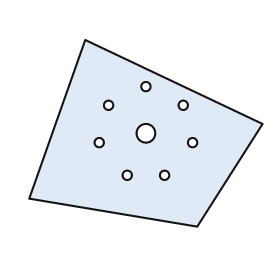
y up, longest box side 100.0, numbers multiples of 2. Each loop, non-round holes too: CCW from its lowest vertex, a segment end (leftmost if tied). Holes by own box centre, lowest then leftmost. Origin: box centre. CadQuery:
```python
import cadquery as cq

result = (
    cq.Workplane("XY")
    .moveTo(22.0, -40.0)
    .lineTo(50.0, 4.0)
    .lineTo(-26.0, 40.0)
    .lineTo(-50.0, -28.0)
    .close()
    .moveTo(-8.0, -18.0)
    .circle(2.0)
    .moveTo(8.0, -18.0)
    .circle(2.0)
    .moveTo(-20.0, -4.0)
    .circle(2.0)
    .moveTo(20.0, -4.0)
    .circle(2.0)
    .moveTo(0.0, 0.0)
    .circle(4.0)
    .moveTo(-16.0, 12.0)
    .circle(2.0)
    .moveTo(16.0, 12.0)
    .circle(2.0)
    .moveTo(0.0, 20.0)
    .circle(2.0)
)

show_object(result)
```